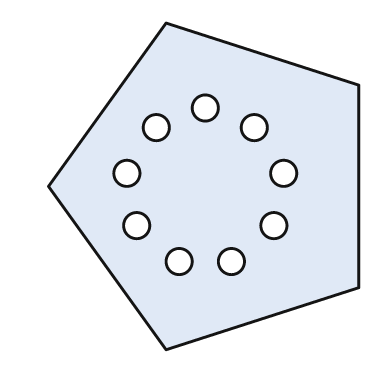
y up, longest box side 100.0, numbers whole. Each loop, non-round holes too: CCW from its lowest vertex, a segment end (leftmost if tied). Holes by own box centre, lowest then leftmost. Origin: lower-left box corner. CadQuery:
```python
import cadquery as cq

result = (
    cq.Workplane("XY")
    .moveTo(36.0, 0.0)
    .lineTo(95.0, 19.0)
    .lineTo(95.0, 81.0)
    .lineTo(36.0, 100.0)
    .lineTo(0.0, 50.0)
    .close()
    .moveTo(40.0, 27.0)
    .circle(4.0)
    .moveTo(56.0, 27.0)
    .circle(4.0)
    .moveTo(27.0, 38.0)
    .circle(4.0)
    .moveTo(69.0, 38.0)
    .circle(4.0)
    .moveTo(24.0, 54.0)
    .circle(4.0)
    .moveTo(72.0, 54.0)
    .circle(4.0)
    .moveTo(33.0, 68.0)
    .circle(4.0)
    .moveTo(63.0, 68.0)
    .circle(4.0)
    .moveTo(48.0, 74.0)
    .circle(4.0)
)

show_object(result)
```